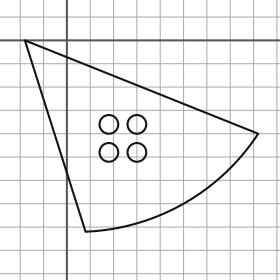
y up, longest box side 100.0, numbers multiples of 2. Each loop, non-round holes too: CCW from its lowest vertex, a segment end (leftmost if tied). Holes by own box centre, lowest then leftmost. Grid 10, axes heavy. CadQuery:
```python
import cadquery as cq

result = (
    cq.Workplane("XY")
    .moveTo(8.0, -82.0)
    .threePointArc((50.0, -70.0), (82.0, -40.0))
    .lineTo(-18.0, 0.0)
    .close()
    .moveTo(18.0, -48.0)
    .circle(4.0)
    .moveTo(30.0, -48.0)
    .circle(4.0)
    .moveTo(18.0, -36.0)
    .circle(4.0)
    .moveTo(30.0, -36.0)
    .circle(4.0)
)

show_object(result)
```